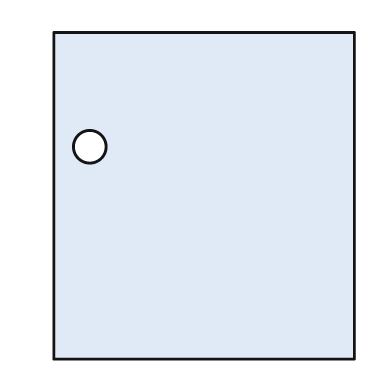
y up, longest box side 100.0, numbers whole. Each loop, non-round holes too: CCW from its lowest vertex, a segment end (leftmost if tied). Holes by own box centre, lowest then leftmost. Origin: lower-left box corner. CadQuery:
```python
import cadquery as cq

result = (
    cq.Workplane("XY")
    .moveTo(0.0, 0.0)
    .lineTo(92.0, 0.0)
    .lineTo(92.0, 100.0)
    .lineTo(0.0, 100.0)
    .close()
    .moveTo(11.0, 65.0)
    .circle(5.0)
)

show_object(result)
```